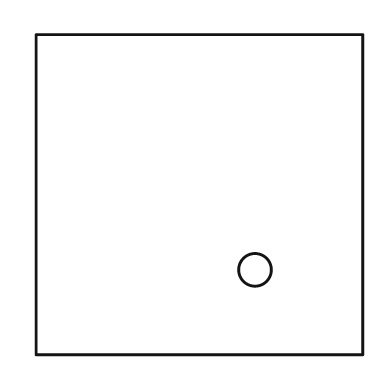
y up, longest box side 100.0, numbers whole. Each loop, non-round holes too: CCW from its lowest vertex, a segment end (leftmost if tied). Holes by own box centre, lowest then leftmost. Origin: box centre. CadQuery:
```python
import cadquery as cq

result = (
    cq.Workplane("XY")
    .moveTo(-50.0, -49.0)
    .lineTo(50.0, -49.0)
    .lineTo(50.0, 49.0)
    .lineTo(-50.0, 49.0)
    .close()
    .moveTo(17.0, -23.0)
    .circle(5.0)
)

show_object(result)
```